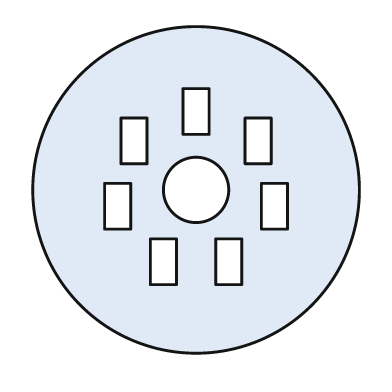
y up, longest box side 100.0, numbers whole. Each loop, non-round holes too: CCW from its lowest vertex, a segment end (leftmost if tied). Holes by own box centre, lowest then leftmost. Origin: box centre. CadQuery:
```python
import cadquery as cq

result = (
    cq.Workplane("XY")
    .moveTo(0.0, 0.0)
    .circle(50.0)
    .moveTo(-14.0, -29.0)
    .lineTo(-6.0, -29.0)
    .lineTo(-6.0, -15.0)
    .lineTo(-14.0, -15.0)
    .close()
    .moveTo(6.0, -29.0)
    .lineTo(14.0, -29.0)
    .lineTo(14.0, -15.0)
    .lineTo(6.0, -15.0)
    .close()
    .moveTo(-28.0, -12.0)
    .lineTo(-20.0, -12.0)
    .lineTo(-20.0, 2.0)
    .lineTo(-28.0, 2.0)
    .close()
    .moveTo(20.0, -12.0)
    .lineTo(28.0, -12.0)
    .lineTo(28.0, 2.0)
    .lineTo(20.0, 2.0)
    .close()
    .moveTo(0.0, 0.0)
    .circle(10.0)
    .moveTo(-23.0, 8.0)
    .lineTo(-15.0, 8.0)
    .lineTo(-15.0, 22.0)
    .lineTo(-23.0, 22.0)
    .close()
    .moveTo(15.0, 8.0)
    .lineTo(23.0, 8.0)
    .lineTo(23.0, 22.0)
    .lineTo(15.0, 22.0)
    .close()
    .moveTo(-4.0, 17.0)
    .lineTo(4.0, 17.0)
    .lineTo(4.0, 31.0)
    .lineTo(-4.0, 31.0)
    .close()
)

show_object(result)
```